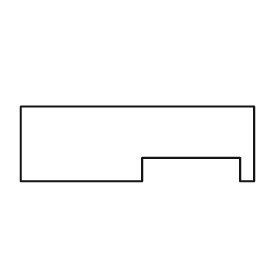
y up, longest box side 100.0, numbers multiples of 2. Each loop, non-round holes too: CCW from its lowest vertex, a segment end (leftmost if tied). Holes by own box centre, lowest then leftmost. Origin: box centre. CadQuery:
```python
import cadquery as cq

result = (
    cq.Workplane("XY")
    .moveTo(-50.0, -16.0)
    .lineTo(2.0, -16.0)
    .lineTo(2.0, -6.0)
    .lineTo(44.0, -6.0)
    .lineTo(44.0, -16.0)
    .lineTo(50.0, -16.0)
    .lineTo(50.0, 16.0)
    .lineTo(-50.0, 16.0)
    .close()
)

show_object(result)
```